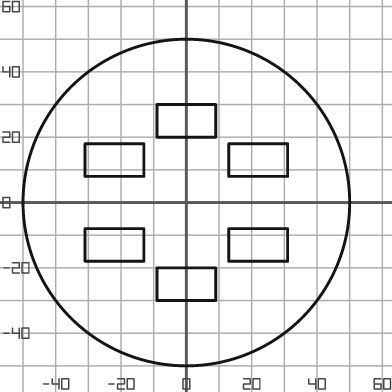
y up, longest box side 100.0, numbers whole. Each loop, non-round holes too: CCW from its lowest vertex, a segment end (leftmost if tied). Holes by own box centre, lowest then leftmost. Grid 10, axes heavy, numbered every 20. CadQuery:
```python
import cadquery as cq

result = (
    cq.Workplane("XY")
    .moveTo(0.0, 0.0)
    .circle(50.0)
    .moveTo(-9.0, -30.0)
    .lineTo(9.0, -30.0)
    .lineTo(9.0, -20.0)
    .lineTo(-9.0, -20.0)
    .close()
    .moveTo(-31.0, -18.0)
    .lineTo(-13.0, -18.0)
    .lineTo(-13.0, -8.0)
    .lineTo(-31.0, -8.0)
    .close()
    .moveTo(13.0, -18.0)
    .lineTo(31.0, -18.0)
    .lineTo(31.0, -8.0)
    .lineTo(13.0, -8.0)
    .close()
    .moveTo(-31.0, 8.0)
    .lineTo(-13.0, 8.0)
    .lineTo(-13.0, 18.0)
    .lineTo(-31.0, 18.0)
    .close()
    .moveTo(13.0, 8.0)
    .lineTo(31.0, 8.0)
    .lineTo(31.0, 18.0)
    .lineTo(13.0, 18.0)
    .close()
    .moveTo(-9.0, 20.0)
    .lineTo(9.0, 20.0)
    .lineTo(9.0, 30.0)
    .lineTo(-9.0, 30.0)
    .close()
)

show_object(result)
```